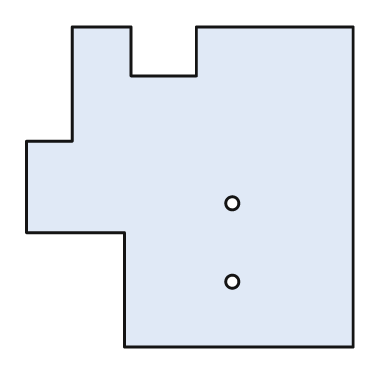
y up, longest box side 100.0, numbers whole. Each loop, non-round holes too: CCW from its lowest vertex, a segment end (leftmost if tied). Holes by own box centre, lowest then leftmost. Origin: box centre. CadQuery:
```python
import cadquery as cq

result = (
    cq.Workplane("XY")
    .moveTo(-20.0, -49.0)
    .lineTo(50.0, -49.0)
    .lineTo(50.0, 49.0)
    .lineTo(2.0, 49.0)
    .lineTo(2.0, 34.0)
    .lineTo(-18.0, 34.0)
    .lineTo(-18.0, 49.0)
    .lineTo(-36.0, 49.0)
    .lineTo(-36.0, 14.0)
    .lineTo(-50.0, 14.0)
    .lineTo(-50.0, -14.0)
    .lineTo(-20.0, -14.0)
    .close()
    .moveTo(13.0, -29.0)
    .circle(2.0)
    .moveTo(13.0, -5.0)
    .circle(2.0)
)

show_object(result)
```